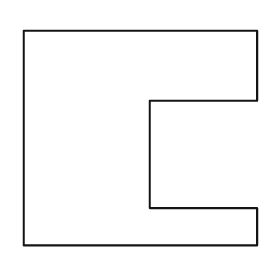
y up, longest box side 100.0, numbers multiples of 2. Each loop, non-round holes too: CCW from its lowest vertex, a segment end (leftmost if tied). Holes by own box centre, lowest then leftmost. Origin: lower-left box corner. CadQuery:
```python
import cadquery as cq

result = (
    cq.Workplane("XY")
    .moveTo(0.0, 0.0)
    .lineTo(100.0, 0.0)
    .lineTo(100.0, 16.0)
    .lineTo(54.0, 16.0)
    .lineTo(54.0, 62.0)
    .lineTo(100.0, 62.0)
    .lineTo(100.0, 92.0)
    .lineTo(0.0, 92.0)
    .close()
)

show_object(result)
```